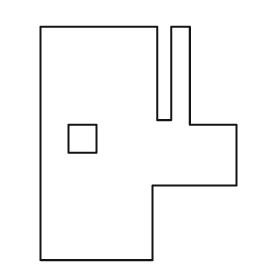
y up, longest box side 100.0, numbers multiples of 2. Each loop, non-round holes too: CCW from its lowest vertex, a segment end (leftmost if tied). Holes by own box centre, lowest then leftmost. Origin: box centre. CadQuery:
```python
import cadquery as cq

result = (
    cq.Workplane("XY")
    .moveTo(-42.0, -50.0)
    .lineTo(6.0, -50.0)
    .lineTo(6.0, -18.0)
    .lineTo(42.0, -18.0)
    .lineTo(42.0, 8.0)
    .lineTo(22.0, 8.0)
    .lineTo(22.0, 50.0)
    .lineTo(14.0, 50.0)
    .lineTo(14.0, 10.0)
    .lineTo(8.0, 10.0)
    .lineTo(8.0, 50.0)
    .lineTo(-42.0, 50.0)
    .close()
    .moveTo(-30.0, -4.0)
    .lineTo(-18.0, -4.0)
    .lineTo(-18.0, 8.0)
    .lineTo(-30.0, 8.0)
    .close()
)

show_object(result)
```